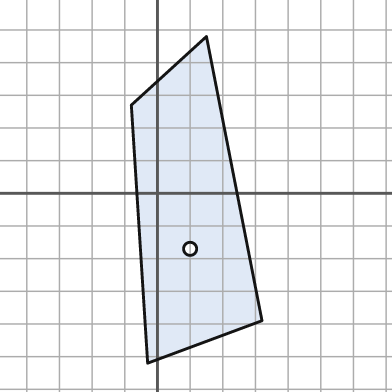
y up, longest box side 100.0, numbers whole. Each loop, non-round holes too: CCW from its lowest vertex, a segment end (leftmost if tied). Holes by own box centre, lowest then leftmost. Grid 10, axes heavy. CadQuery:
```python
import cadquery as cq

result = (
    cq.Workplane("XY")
    .moveTo(-3.0, -52.0)
    .lineTo(32.0, -39.0)
    .lineTo(15.0, 48.0)
    .lineTo(-8.0, 27.0)
    .close()
    .moveTo(10.0, -17.0)
    .circle(2.0)
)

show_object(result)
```